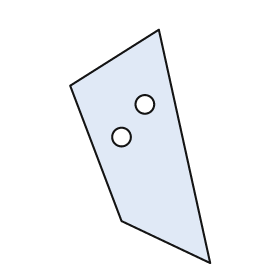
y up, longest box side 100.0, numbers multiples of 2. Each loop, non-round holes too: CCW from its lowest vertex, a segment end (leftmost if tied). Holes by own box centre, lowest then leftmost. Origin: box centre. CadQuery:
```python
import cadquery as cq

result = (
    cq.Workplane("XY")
    .moveTo(30.0, -50.0)
    .lineTo(8.0, 50.0)
    .lineTo(-30.0, 26.0)
    .lineTo(-8.0, -32.0)
    .close()
    .moveTo(-8.0, 4.0)
    .circle(4.0)
    .moveTo(2.0, 18.0)
    .circle(4.0)
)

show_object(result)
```